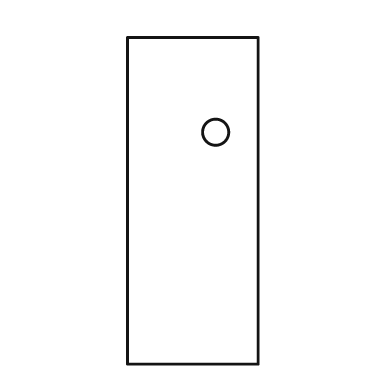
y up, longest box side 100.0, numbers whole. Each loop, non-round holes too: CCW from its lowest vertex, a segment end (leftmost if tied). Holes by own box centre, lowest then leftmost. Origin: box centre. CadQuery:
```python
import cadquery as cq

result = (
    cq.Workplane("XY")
    .moveTo(-20.0, -50.0)
    .lineTo(20.0, -50.0)
    .lineTo(20.0, 50.0)
    .lineTo(-20.0, 50.0)
    .close()
    .moveTo(7.0, 21.0)
    .circle(4.0)
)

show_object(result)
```